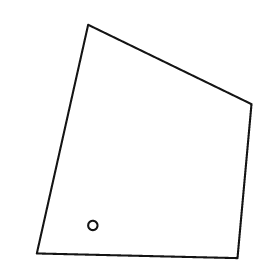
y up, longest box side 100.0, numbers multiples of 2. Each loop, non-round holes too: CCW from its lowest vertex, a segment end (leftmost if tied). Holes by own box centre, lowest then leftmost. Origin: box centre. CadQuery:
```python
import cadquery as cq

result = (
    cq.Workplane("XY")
    .moveTo(40.0, -50.0)
    .lineTo(46.0, 16.0)
    .lineTo(-24.0, 50.0)
    .lineTo(-46.0, -48.0)
    .close()
    .moveTo(-22.0, -36.0)
    .circle(2.0)
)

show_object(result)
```